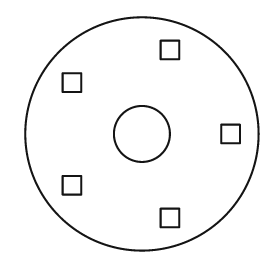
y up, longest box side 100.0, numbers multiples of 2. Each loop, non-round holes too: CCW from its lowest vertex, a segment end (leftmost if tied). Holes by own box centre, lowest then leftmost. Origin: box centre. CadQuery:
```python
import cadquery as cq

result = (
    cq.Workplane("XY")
    .moveTo(0.0, 0.0)
    .circle(50.0)
    .moveTo(8.0, -40.0)
    .lineTo(16.0, -40.0)
    .lineTo(16.0, -32.0)
    .lineTo(8.0, -32.0)
    .close()
    .moveTo(-34.0, -26.0)
    .lineTo(-26.0, -26.0)
    .lineTo(-26.0, -18.0)
    .lineTo(-34.0, -18.0)
    .close()
    .moveTo(0.0, 0.0)
    .circle(12.0)
    .moveTo(34.0, -4.0)
    .lineTo(42.0, -4.0)
    .lineTo(42.0, 4.0)
    .lineTo(34.0, 4.0)
    .close()
    .moveTo(-34.0, 18.0)
    .lineTo(-26.0, 18.0)
    .lineTo(-26.0, 26.0)
    .lineTo(-34.0, 26.0)
    .close()
    .moveTo(8.0, 32.0)
    .lineTo(16.0, 32.0)
    .lineTo(16.0, 40.0)
    .lineTo(8.0, 40.0)
    .close()
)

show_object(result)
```